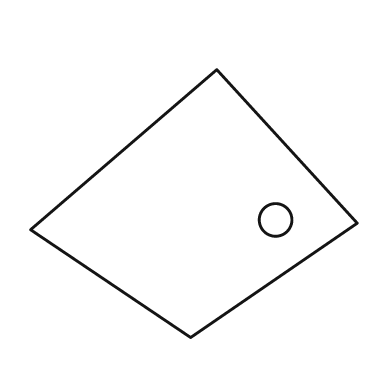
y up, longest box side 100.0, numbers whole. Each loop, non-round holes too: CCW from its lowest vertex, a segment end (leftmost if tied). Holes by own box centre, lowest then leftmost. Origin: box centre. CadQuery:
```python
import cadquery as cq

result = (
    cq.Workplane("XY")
    .moveTo(-1.0, -41.0)
    .lineTo(50.0, -6.0)
    .lineTo(7.0, 41.0)
    .lineTo(-50.0, -8.0)
    .close()
    .moveTo(25.0, -5.0)
    .circle(5.0)
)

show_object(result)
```